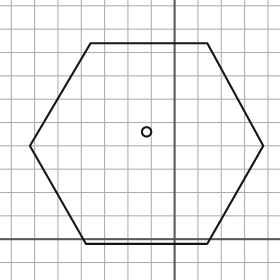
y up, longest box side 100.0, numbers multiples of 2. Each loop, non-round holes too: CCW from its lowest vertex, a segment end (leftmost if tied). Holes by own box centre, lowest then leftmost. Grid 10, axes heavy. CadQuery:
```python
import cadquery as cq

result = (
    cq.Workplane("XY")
    .moveTo(-38.0, -2.0)
    .lineTo(14.0, -2.0)
    .lineTo(38.0, 40.0)
    .lineTo(14.0, 84.0)
    .lineTo(-36.0, 84.0)
    .lineTo(-62.0, 40.0)
    .close()
    .moveTo(-12.0, 46.0)
    .circle(2.0)
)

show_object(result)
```